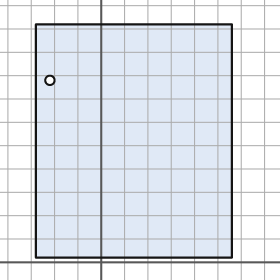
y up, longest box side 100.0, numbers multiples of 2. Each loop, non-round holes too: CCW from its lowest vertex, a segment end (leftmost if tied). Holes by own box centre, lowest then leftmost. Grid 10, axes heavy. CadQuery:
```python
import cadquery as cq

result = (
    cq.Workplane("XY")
    .moveTo(-28.0, 2.0)
    .lineTo(56.0, 2.0)
    .lineTo(56.0, 102.0)
    .lineTo(-28.0, 102.0)
    .close()
    .moveTo(-22.0, 78.0)
    .circle(2.0)
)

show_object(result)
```